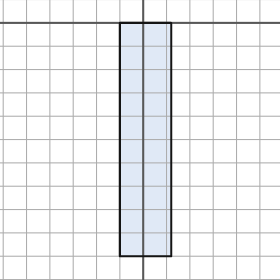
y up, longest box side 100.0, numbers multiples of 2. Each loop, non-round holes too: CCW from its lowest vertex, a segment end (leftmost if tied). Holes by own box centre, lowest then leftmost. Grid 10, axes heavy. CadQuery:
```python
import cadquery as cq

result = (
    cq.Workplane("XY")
    .moveTo(-10.0, -100.0)
    .lineTo(12.0, -100.0)
    .lineTo(12.0, 0.0)
    .lineTo(-10.0, 0.0)
    .close()
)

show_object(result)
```